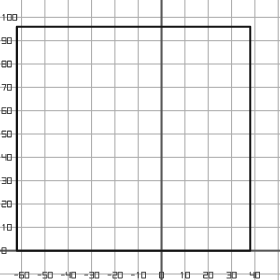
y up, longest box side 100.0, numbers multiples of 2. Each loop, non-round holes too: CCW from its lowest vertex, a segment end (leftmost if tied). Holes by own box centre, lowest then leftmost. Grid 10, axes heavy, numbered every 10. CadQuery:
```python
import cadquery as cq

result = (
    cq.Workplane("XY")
    .moveTo(-62.0, 0.0)
    .lineTo(38.0, 0.0)
    .lineTo(38.0, 96.0)
    .lineTo(-62.0, 96.0)
    .close()
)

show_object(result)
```